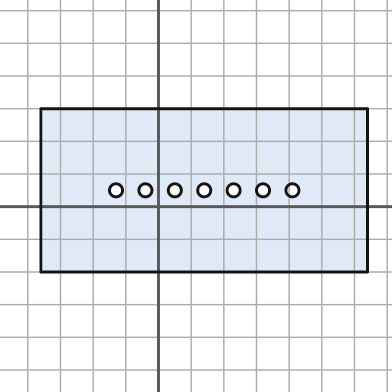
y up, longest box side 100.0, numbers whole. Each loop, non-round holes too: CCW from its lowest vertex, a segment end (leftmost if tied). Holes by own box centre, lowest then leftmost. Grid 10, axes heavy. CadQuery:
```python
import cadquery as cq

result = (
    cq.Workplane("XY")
    .moveTo(-36.0, -20.0)
    .lineTo(64.0, -20.0)
    .lineTo(64.0, 30.0)
    .lineTo(-36.0, 30.0)
    .close()
    .moveTo(-13.0, 5.0)
    .circle(2.0)
    .moveTo(-4.0, 5.0)
    .circle(2.0)
    .moveTo(5.0, 5.0)
    .circle(2.0)
    .moveTo(14.0, 5.0)
    .circle(2.0)
    .moveTo(23.0, 5.0)
    .circle(2.0)
    .moveTo(32.0, 5.0)
    .circle(2.0)
    .moveTo(41.0, 5.0)
    .circle(2.0)
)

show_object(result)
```